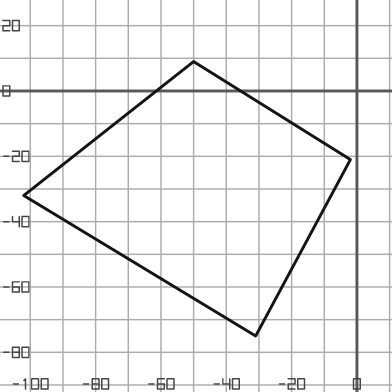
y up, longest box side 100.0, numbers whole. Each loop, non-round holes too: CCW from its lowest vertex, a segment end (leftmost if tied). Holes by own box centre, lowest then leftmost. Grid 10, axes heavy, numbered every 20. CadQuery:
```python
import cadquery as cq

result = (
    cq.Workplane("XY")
    .moveTo(-31.0, -75.0)
    .lineTo(-2.0, -21.0)
    .lineTo(-50.0, 9.0)
    .lineTo(-102.0, -32.0)
    .close()
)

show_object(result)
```